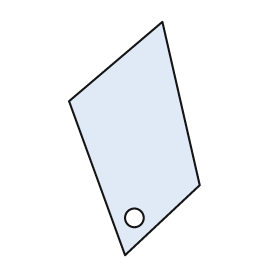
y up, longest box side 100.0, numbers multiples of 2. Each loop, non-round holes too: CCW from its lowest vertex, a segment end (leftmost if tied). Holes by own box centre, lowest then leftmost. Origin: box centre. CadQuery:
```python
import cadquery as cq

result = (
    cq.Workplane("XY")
    .moveTo(-4.0, -50.0)
    .lineTo(28.0, -20.0)
    .lineTo(12.0, 50.0)
    .lineTo(-28.0, 16.0)
    .close()
    .moveTo(0.0, -34.0)
    .circle(4.0)
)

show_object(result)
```